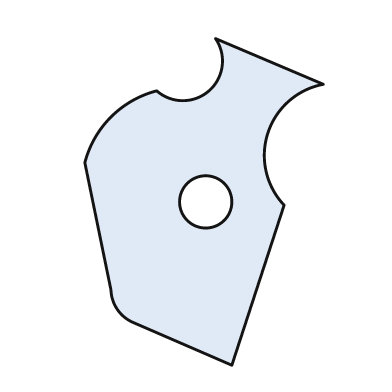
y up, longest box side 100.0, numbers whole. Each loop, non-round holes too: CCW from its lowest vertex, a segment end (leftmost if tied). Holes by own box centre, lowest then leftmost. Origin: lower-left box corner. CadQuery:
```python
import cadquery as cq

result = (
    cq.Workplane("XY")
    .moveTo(45.0, 0.0)
    .lineTo(61.0, 49.0)
    .threePointArc((56.0, 71.0), (73.0, 86.0))
    .lineTo(40.0, 100.0)
    .threePointArc((38.0, 84.0), (22.0, 84.0))
    .threePointArc((8.0, 76.0), (0.0, 62.0))
    .lineTo(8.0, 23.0)
    .threePointArc((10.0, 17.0), (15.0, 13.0))
    .close()
    .moveTo(37.0, 50.0)
    .circle(8.0)
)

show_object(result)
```